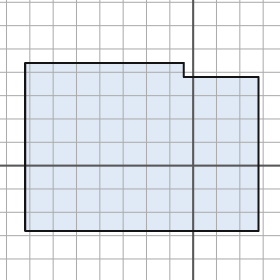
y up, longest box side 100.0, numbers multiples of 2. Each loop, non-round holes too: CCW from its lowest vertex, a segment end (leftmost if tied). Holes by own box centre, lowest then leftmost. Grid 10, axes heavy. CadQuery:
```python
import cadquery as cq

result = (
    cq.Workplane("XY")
    .moveTo(-72.0, -28.0)
    .lineTo(28.0, -28.0)
    .lineTo(28.0, 38.0)
    .lineTo(-4.0, 38.0)
    .lineTo(-4.0, 44.0)
    .lineTo(-72.0, 44.0)
    .close()
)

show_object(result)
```